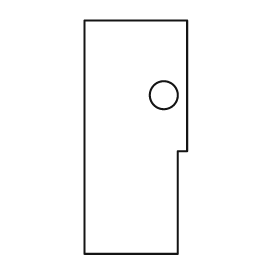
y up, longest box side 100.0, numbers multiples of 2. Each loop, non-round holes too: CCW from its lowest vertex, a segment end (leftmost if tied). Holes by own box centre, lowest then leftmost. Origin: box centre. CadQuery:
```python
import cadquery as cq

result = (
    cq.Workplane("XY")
    .moveTo(-22.0, -50.0)
    .lineTo(18.0, -50.0)
    .lineTo(18.0, -6.0)
    .lineTo(22.0, -6.0)
    .lineTo(22.0, 50.0)
    .lineTo(-22.0, 50.0)
    .close()
    .moveTo(12.0, 18.0)
    .circle(6.0)
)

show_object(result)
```